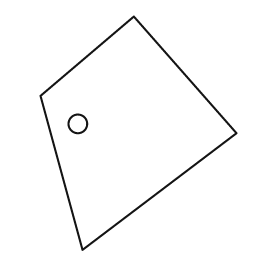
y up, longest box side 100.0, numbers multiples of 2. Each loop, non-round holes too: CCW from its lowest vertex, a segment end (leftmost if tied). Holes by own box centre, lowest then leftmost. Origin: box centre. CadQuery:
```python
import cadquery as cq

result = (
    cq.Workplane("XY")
    .moveTo(-24.0, -50.0)
    .lineTo(42.0, 0.0)
    .lineTo(-2.0, 50.0)
    .lineTo(-42.0, 16.0)
    .close()
    .moveTo(-26.0, 4.0)
    .circle(4.0)
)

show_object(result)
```